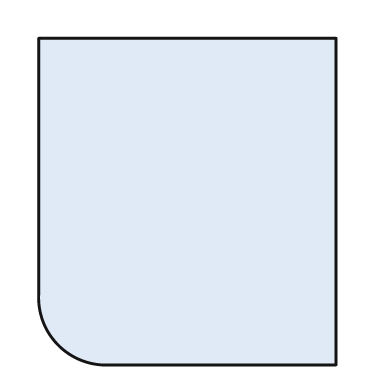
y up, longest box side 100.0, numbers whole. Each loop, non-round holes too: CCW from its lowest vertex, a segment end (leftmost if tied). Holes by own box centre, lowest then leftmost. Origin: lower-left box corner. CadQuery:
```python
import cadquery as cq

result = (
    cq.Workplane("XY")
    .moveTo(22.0, 0.0)
    .lineTo(91.0, 0.0)
    .lineTo(91.0, 100.0)
    .lineTo(0.0, 100.0)
    .lineTo(0.0, 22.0)
    .threePointArc((6.0, 6.0), (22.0, 0.0))
    .close()
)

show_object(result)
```